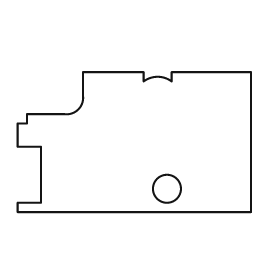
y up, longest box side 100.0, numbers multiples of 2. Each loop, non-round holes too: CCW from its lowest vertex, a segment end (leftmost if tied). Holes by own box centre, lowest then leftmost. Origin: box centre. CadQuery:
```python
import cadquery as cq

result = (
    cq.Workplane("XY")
    .moveTo(-50.0, -30.0)
    .lineTo(50.0, -30.0)
    .lineTo(50.0, 30.0)
    .lineTo(16.0, 30.0)
    .lineTo(16.0, 26.0)
    .threePointArc((10.0, 28.0), (4.0, 26.0))
    .lineTo(4.0, 30.0)
    .lineTo(-22.0, 30.0)
    .lineTo(-22.0, 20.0)
    .threePointArc((-24.0, 14.0), (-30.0, 12.0))
    .lineTo(-46.0, 12.0)
    .lineTo(-46.0, 8.0)
    .lineTo(-50.0, 8.0)
    .lineTo(-50.0, -2.0)
    .lineTo(-40.0, -2.0)
    .lineTo(-40.0, -26.0)
    .lineTo(-50.0, -26.0)
    .close()
    .moveTo(14.0, -20.0)
    .circle(6.0)
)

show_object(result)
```